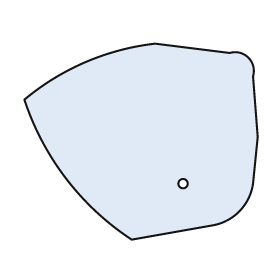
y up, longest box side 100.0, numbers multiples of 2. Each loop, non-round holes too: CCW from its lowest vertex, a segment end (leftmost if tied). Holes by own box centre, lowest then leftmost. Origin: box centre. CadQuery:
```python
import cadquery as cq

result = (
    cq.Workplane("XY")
    .moveTo(-4.0, -42.0)
    .lineTo(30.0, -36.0)
    .threePointArc((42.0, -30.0), (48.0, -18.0))
    .lineTo(50.0, 2.0)
    .lineTo(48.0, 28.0)
    .threePointArc((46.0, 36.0), (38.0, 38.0))
    .lineTo(6.0, 42.0)
    .threePointArc((-24.0, 34.0), (-50.0, 18.0))
    .threePointArc((-32.0, -16.0), (-4.0, -42.0))
    .close()
    .moveTo(18.0, -18.0)
    .circle(2.0)
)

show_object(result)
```